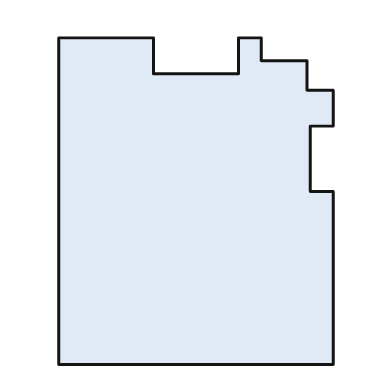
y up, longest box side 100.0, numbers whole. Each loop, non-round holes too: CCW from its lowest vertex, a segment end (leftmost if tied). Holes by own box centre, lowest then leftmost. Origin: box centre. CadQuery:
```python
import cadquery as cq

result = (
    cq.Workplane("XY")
    .moveTo(-42.0, -50.0)
    .lineTo(42.0, -50.0)
    .lineTo(42.0, 3.0)
    .lineTo(35.0, 3.0)
    .lineTo(35.0, 23.0)
    .lineTo(42.0, 23.0)
    .lineTo(42.0, 34.0)
    .lineTo(34.0, 34.0)
    .lineTo(34.0, 43.0)
    .lineTo(20.0, 43.0)
    .lineTo(20.0, 50.0)
    .lineTo(13.0, 50.0)
    .lineTo(13.0, 39.0)
    .lineTo(-13.0, 39.0)
    .lineTo(-13.0, 50.0)
    .lineTo(-42.0, 50.0)
    .close()
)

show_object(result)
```